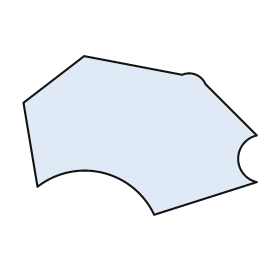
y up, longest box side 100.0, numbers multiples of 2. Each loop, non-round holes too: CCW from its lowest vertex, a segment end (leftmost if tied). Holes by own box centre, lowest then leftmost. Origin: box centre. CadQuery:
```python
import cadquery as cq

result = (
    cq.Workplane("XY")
    .moveTo(6.0, -34.0)
    .lineTo(50.0, -20.0)
    .threePointArc((42.0, -10.0), (50.0, 0.0))
    .lineTo(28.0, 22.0)
    .threePointArc((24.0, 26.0), (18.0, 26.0))
    .lineTo(-24.0, 34.0)
    .lineTo(-50.0, 14.0)
    .lineTo(-44.0, -22.0)
    .threePointArc((-16.0, -16.0), (6.0, -34.0))
    .close()
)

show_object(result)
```